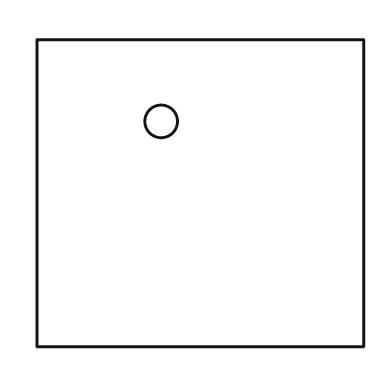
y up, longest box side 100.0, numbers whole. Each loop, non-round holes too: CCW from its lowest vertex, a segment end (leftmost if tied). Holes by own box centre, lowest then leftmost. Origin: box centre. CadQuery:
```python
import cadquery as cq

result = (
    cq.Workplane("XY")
    .moveTo(-50.0, -47.0)
    .lineTo(50.0, -47.0)
    .lineTo(50.0, 47.0)
    .lineTo(-50.0, 47.0)
    .close()
    .moveTo(-12.0, 22.0)
    .circle(5.0)
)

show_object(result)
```